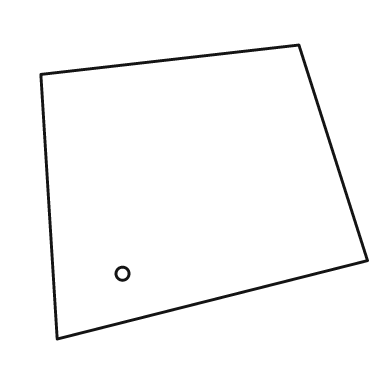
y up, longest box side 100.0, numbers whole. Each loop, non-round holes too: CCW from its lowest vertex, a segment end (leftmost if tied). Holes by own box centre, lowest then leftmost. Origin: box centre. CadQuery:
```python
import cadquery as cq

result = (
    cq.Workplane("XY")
    .moveTo(-45.0, -45.0)
    .lineTo(50.0, -21.0)
    .lineTo(29.0, 45.0)
    .lineTo(-50.0, 36.0)
    .close()
    .moveTo(-25.0, -25.0)
    .circle(2.0)
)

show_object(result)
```